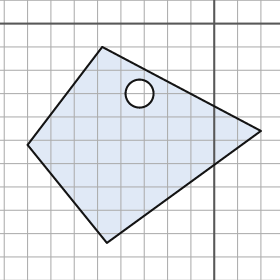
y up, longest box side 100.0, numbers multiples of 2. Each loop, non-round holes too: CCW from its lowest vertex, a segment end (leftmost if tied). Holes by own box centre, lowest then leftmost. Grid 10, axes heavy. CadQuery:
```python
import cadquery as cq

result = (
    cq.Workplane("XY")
    .moveTo(-46.0, -94.0)
    .lineTo(20.0, -46.0)
    .lineTo(-48.0, -10.0)
    .lineTo(-80.0, -52.0)
    .close()
    .moveTo(-32.0, -30.0)
    .circle(6.0)
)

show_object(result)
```